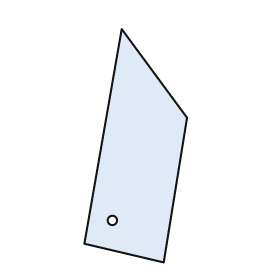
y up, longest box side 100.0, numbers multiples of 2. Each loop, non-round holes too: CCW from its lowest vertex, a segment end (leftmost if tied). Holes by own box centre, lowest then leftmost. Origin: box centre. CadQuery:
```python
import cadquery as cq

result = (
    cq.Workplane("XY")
    .moveTo(12.0, -50.0)
    .lineTo(22.0, 12.0)
    .lineTo(-6.0, 50.0)
    .lineTo(-22.0, -42.0)
    .close()
    .moveTo(-10.0, -32.0)
    .circle(2.0)
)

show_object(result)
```